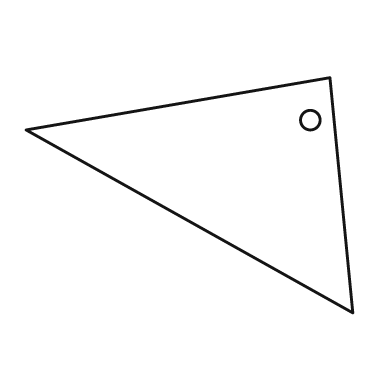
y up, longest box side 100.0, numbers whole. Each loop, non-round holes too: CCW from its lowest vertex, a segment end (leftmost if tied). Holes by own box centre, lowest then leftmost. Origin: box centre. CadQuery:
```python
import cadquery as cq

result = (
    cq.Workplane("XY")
    .moveTo(50.0, -36.0)
    .lineTo(43.0, 36.0)
    .lineTo(-50.0, 20.0)
    .close()
    .moveTo(37.0, 23.0)
    .circle(3.0)
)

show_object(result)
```